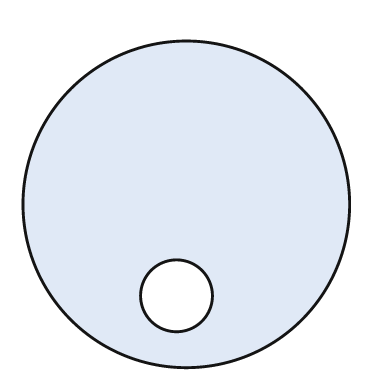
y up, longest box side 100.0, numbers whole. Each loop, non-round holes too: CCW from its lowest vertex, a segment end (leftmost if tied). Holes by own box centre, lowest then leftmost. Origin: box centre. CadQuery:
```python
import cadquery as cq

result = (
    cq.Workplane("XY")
    .moveTo(0.0, 0.0)
    .circle(50.0)
    .moveTo(-3.0, -28.0)
    .circle(11.0)
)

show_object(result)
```